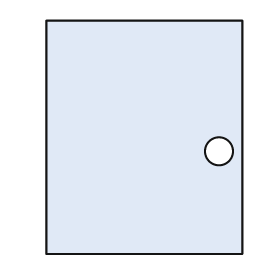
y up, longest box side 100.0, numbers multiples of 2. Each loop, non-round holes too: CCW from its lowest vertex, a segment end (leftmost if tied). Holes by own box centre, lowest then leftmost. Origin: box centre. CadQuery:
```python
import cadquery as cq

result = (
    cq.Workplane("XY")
    .moveTo(-42.0, -50.0)
    .lineTo(42.0, -50.0)
    .lineTo(42.0, 50.0)
    .lineTo(-42.0, 50.0)
    .close()
    .moveTo(32.0, -6.0)
    .circle(6.0)
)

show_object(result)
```